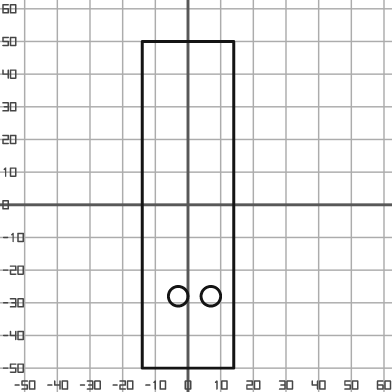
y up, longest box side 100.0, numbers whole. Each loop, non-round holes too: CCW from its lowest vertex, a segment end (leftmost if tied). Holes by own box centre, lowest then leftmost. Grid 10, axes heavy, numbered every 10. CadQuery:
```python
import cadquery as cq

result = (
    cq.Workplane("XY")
    .moveTo(-14.0, -50.0)
    .lineTo(14.0, -50.0)
    .lineTo(14.0, 50.0)
    .lineTo(-14.0, 50.0)
    .close()
    .moveTo(-3.0, -28.0)
    .circle(3.0)
    .moveTo(7.0, -28.0)
    .circle(3.0)
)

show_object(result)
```